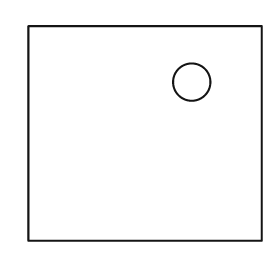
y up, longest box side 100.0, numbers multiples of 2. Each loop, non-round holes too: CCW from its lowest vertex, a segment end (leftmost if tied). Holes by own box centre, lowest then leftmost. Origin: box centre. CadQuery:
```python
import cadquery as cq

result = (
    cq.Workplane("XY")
    .moveTo(-50.0, -46.0)
    .lineTo(50.0, -46.0)
    .lineTo(50.0, 46.0)
    .lineTo(-50.0, 46.0)
    .close()
    .moveTo(20.0, 22.0)
    .circle(8.0)
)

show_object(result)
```